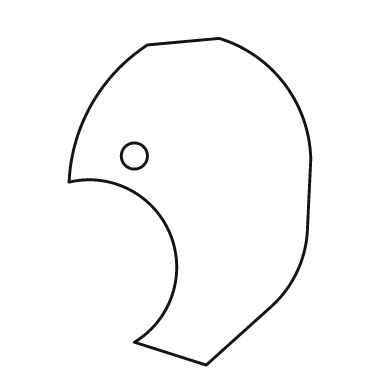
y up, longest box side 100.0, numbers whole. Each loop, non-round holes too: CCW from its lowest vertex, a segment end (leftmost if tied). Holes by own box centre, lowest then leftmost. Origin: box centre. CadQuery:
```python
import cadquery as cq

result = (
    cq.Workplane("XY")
    .moveTo(5.0, -50.0)
    .lineTo(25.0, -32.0)
    .threePointArc((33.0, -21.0), (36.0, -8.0))
    .lineTo(37.0, 13.0)
    .threePointArc((29.0, 36.0), (9.0, 50.0))
    .lineTo(-13.0, 48.0)
    .threePointArc((-30.0, 30.0), (-37.0, 6.0))
    .threePointArc((-6.0, -10.0), (-17.0, -43.0))
    .close()
    .moveTo(-17.0, 14.0)
    .circle(4.0)
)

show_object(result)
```